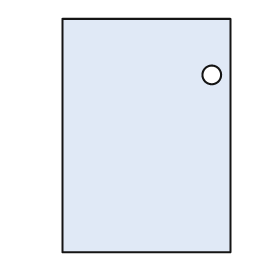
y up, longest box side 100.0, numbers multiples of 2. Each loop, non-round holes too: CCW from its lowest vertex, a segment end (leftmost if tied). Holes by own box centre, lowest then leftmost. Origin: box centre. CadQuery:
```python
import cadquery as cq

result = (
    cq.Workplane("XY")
    .moveTo(-36.0, -50.0)
    .lineTo(36.0, -50.0)
    .lineTo(36.0, 50.0)
    .lineTo(-36.0, 50.0)
    .close()
    .moveTo(28.0, 26.0)
    .circle(4.0)
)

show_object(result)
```